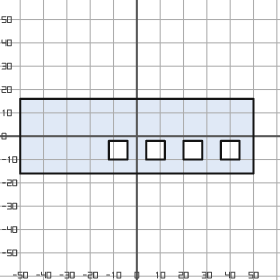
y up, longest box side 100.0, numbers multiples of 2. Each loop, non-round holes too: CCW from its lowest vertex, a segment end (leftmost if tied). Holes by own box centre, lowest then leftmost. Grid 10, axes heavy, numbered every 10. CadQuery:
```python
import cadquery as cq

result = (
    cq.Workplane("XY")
    .moveTo(-50.0, -16.0)
    .lineTo(50.0, -16.0)
    .lineTo(50.0, 16.0)
    .lineTo(-50.0, 16.0)
    .close()
    .moveTo(-12.0, -10.0)
    .lineTo(-4.0, -10.0)
    .lineTo(-4.0, -2.0)
    .lineTo(-12.0, -2.0)
    .close()
    .moveTo(4.0, -10.0)
    .lineTo(12.0, -10.0)
    .lineTo(12.0, -2.0)
    .lineTo(4.0, -2.0)
    .close()
    .moveTo(20.0, -10.0)
    .lineTo(28.0, -10.0)
    .lineTo(28.0, -2.0)
    .lineTo(20.0, -2.0)
    .close()
    .moveTo(36.0, -10.0)
    .lineTo(44.0, -10.0)
    .lineTo(44.0, -2.0)
    .lineTo(36.0, -2.0)
    .close()
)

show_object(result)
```